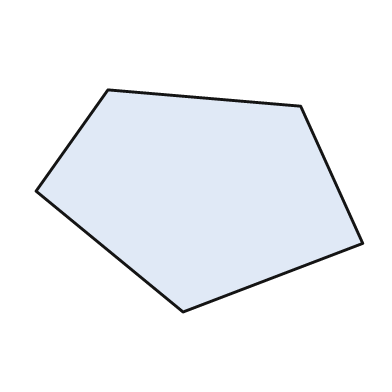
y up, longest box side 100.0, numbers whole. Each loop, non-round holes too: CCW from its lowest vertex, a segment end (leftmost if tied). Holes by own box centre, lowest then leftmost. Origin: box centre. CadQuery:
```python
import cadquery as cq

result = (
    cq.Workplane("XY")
    .moveTo(-5.0, -34.0)
    .lineTo(50.0, -13.0)
    .lineTo(31.0, 29.0)
    .lineTo(-28.0, 34.0)
    .lineTo(-50.0, 3.0)
    .close()
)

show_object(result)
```